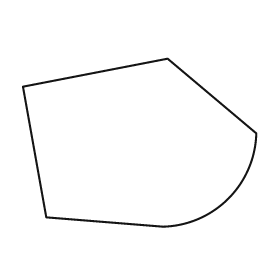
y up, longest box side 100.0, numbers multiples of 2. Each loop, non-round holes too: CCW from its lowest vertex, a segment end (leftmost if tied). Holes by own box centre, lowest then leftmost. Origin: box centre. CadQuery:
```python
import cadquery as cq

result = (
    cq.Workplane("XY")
    .moveTo(10.0, -36.0)
    .threePointArc((38.0, -24.0), (50.0, 4.0))
    .lineTo(12.0, 36.0)
    .lineTo(-50.0, 24.0)
    .lineTo(-40.0, -32.0)
    .close()
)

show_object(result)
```